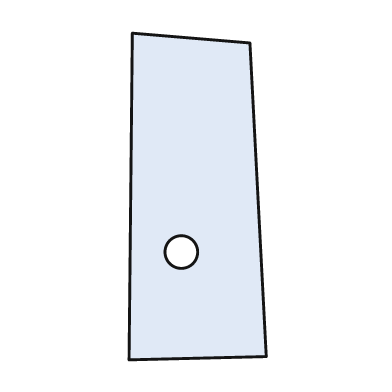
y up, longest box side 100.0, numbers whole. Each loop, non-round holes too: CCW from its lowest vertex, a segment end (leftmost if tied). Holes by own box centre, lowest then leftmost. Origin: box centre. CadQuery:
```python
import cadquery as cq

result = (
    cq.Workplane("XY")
    .moveTo(-21.0, -50.0)
    .lineTo(21.0, -49.0)
    .lineTo(16.0, 47.0)
    .lineTo(-20.0, 50.0)
    .close()
    .moveTo(-5.0, -17.0)
    .circle(5.0)
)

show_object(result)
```